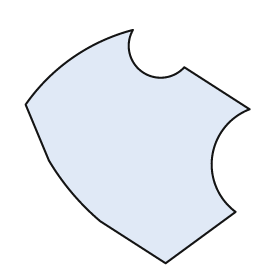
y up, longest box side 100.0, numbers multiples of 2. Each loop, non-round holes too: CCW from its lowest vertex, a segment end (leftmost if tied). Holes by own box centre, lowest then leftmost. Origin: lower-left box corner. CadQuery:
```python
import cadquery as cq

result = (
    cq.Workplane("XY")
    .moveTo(60.0, 0.0)
    .lineTo(90.0, 22.0)
    .threePointArc((80.0, 46.0), (96.0, 66.0))
    .lineTo(68.0, 84.0)
    .threePointArc((50.0, 82.0), (46.0, 100.0))
    .threePointArc((20.0, 88.0), (0.0, 68.0))
    .lineTo(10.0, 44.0)
    .threePointArc((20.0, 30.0), (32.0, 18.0))
    .close()
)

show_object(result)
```